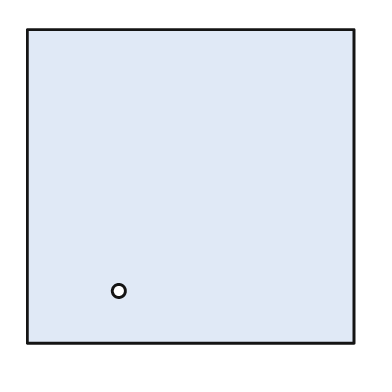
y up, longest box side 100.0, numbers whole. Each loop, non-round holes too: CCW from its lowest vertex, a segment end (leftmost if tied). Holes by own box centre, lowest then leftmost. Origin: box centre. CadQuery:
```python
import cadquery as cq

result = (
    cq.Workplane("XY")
    .moveTo(-50.0, -48.0)
    .lineTo(50.0, -48.0)
    .lineTo(50.0, 48.0)
    .lineTo(-50.0, 48.0)
    .close()
    .moveTo(-22.0, -32.0)
    .circle(2.0)
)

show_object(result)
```